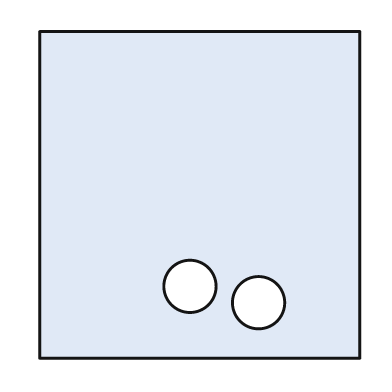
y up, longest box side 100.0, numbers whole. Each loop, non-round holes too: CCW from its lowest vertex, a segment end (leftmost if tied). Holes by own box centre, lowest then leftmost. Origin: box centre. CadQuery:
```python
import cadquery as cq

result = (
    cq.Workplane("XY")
    .moveTo(-49.0, -50.0)
    .lineTo(49.0, -50.0)
    .lineTo(49.0, 50.0)
    .lineTo(-49.0, 50.0)
    .close()
    .moveTo(18.0, -33.0)
    .circle(8.0)
    .moveTo(-3.0, -28.0)
    .circle(8.0)
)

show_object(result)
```